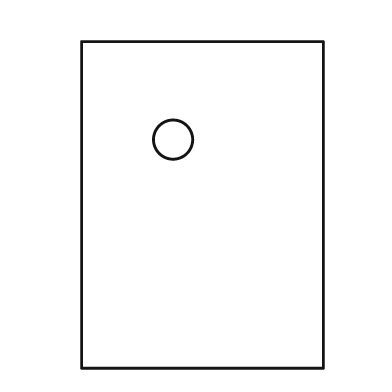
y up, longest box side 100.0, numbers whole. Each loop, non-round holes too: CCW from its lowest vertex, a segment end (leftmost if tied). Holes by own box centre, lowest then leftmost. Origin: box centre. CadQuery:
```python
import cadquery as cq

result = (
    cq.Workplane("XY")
    .moveTo(-37.0, -50.0)
    .lineTo(37.0, -50.0)
    .lineTo(37.0, 50.0)
    .lineTo(-37.0, 50.0)
    .close()
    .moveTo(-9.0, 20.0)
    .circle(6.0)
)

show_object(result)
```